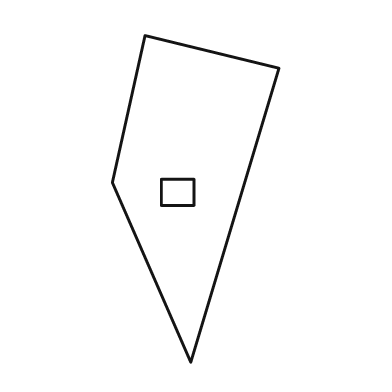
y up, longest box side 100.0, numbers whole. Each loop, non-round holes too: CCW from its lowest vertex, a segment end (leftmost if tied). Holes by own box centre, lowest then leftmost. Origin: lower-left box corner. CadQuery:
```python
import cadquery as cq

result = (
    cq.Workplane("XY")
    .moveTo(24.0, 0.0)
    .lineTo(51.0, 90.0)
    .lineTo(10.0, 100.0)
    .lineTo(0.0, 55.0)
    .close()
    .moveTo(15.0, 48.0)
    .lineTo(25.0, 48.0)
    .lineTo(25.0, 56.0)
    .lineTo(15.0, 56.0)
    .close()
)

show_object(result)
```